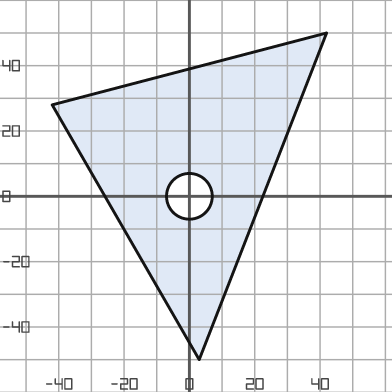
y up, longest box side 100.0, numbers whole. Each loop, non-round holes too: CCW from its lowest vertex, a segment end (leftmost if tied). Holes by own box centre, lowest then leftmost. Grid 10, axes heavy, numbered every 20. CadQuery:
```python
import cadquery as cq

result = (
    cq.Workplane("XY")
    .moveTo(3.0, -50.0)
    .lineTo(42.0, 50.0)
    .lineTo(-42.0, 28.0)
    .close()
    .moveTo(0.0, 0.0)
    .circle(7.0)
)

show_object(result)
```